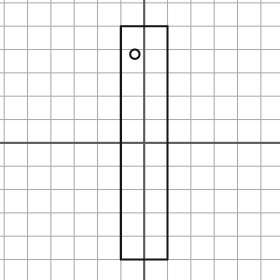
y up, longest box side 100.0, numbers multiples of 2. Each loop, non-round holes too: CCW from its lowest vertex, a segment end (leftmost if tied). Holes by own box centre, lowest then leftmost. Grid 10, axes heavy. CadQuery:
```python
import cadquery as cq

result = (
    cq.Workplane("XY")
    .moveTo(-10.0, -50.0)
    .lineTo(10.0, -50.0)
    .lineTo(10.0, 50.0)
    .lineTo(-10.0, 50.0)
    .close()
    .moveTo(-4.0, 38.0)
    .circle(2.0)
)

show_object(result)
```